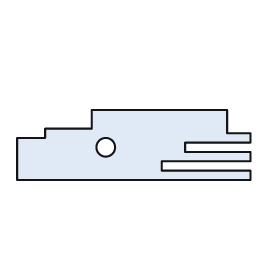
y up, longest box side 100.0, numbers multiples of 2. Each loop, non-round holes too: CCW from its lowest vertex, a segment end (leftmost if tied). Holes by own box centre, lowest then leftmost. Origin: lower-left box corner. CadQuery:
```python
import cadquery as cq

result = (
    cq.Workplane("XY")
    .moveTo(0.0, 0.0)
    .lineTo(100.0, 0.0)
    .lineTo(100.0, 4.0)
    .lineTo(62.0, 4.0)
    .lineTo(62.0, 8.0)
    .lineTo(100.0, 8.0)
    .lineTo(100.0, 12.0)
    .lineTo(72.0, 12.0)
    .lineTo(72.0, 16.0)
    .lineTo(100.0, 16.0)
    .lineTo(100.0, 20.0)
    .lineTo(90.0, 20.0)
    .lineTo(90.0, 30.0)
    .lineTo(32.0, 30.0)
    .lineTo(32.0, 22.0)
    .lineTo(12.0, 22.0)
    .lineTo(12.0, 18.0)
    .lineTo(0.0, 18.0)
    .close()
    .moveTo(38.0, 14.0)
    .circle(4.0)
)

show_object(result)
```